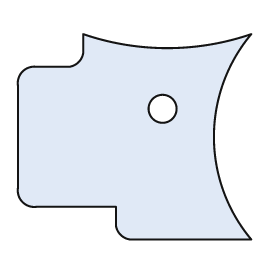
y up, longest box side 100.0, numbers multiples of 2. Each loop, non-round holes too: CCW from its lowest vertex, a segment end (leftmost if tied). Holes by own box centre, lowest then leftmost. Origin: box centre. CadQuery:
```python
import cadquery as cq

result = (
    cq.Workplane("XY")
    .moveTo(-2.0, -44.0)
    .lineTo(50.0, -44.0)
    .threePointArc((34.0, 0.0), (50.0, 44.0))
    .threePointArc((14.0, 38.0), (-22.0, 44.0))
    .lineTo(-22.0, 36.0)
    .threePointArc((-24.0, 32.0), (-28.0, 30.0))
    .lineTo(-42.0, 30.0)
    .threePointArc((-48.0, 28.0), (-50.0, 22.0))
    .lineTo(-50.0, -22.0)
    .threePointArc((-48.0, -28.0), (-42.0, -30.0))
    .lineTo(-8.0, -30.0)
    .lineTo(-8.0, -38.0)
    .threePointArc((-6.0, -42.0), (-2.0, -44.0))
    .close()
    .moveTo(12.0, 12.0)
    .circle(6.0)
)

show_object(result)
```